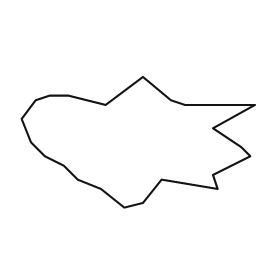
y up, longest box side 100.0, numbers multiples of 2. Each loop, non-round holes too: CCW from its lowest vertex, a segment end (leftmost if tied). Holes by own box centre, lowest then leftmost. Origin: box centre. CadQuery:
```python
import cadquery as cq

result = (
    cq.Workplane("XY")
    .moveTo(-6.0, -28.0)
    .lineTo(2.0, -26.0)
    .lineTo(10.0, -16.0)
    .lineTo(34.0, -20.0)
    .lineTo(32.0, -14.0)
    .lineTo(48.0, -6.0)
    .lineTo(44.0, -2.0)
    .lineTo(32.0, 6.0)
    .lineTo(50.0, 16.0)
    .lineTo(20.0, 16.0)
    .lineTo(14.0, 18.0)
    .lineTo(2.0, 28.0)
    .lineTo(-14.0, 16.0)
    .lineTo(-30.0, 20.0)
    .lineTo(-38.0, 20.0)
    .lineTo(-44.0, 18.0)
    .lineTo(-50.0, 10.0)
    .lineTo(-46.0, 0.0)
    .lineTo(-40.0, -6.0)
    .lineTo(-32.0, -10.0)
    .lineTo(-26.0, -16.0)
    .lineTo(-16.0, -20.0)
    .close()
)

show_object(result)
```